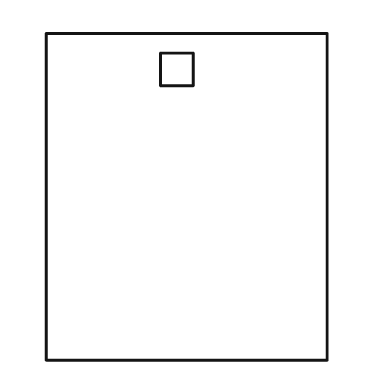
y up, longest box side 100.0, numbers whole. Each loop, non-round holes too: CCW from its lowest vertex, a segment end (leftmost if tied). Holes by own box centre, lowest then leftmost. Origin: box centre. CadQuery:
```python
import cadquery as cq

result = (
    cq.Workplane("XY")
    .moveTo(-43.0, -50.0)
    .lineTo(43.0, -50.0)
    .lineTo(43.0, 50.0)
    .lineTo(-43.0, 50.0)
    .close()
    .moveTo(-8.0, 34.0)
    .lineTo(2.0, 34.0)
    .lineTo(2.0, 44.0)
    .lineTo(-8.0, 44.0)
    .close()
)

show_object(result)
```